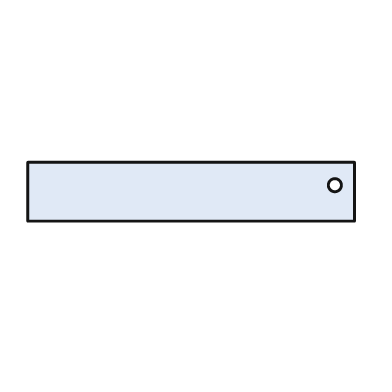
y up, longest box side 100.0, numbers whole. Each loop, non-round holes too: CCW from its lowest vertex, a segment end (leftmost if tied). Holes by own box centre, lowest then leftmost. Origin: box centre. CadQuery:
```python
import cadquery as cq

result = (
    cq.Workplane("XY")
    .moveTo(-50.0, -9.0)
    .lineTo(50.0, -9.0)
    .lineTo(50.0, 9.0)
    .lineTo(-50.0, 9.0)
    .close()
    .moveTo(44.0, 2.0)
    .circle(2.0)
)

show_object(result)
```